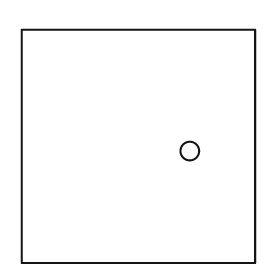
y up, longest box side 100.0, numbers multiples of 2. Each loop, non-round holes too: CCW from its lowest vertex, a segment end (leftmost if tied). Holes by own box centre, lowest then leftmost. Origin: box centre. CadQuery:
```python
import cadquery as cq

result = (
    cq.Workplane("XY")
    .moveTo(-50.0, -50.0)
    .lineTo(50.0, -50.0)
    .lineTo(50.0, 50.0)
    .lineTo(-50.0, 50.0)
    .close()
    .moveTo(22.0, -2.0)
    .circle(4.0)
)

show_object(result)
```